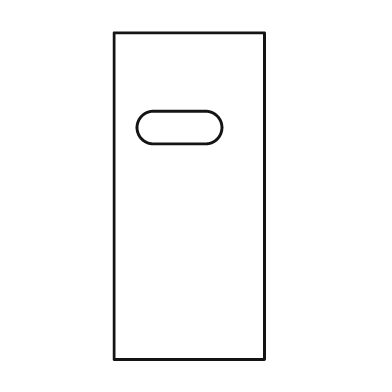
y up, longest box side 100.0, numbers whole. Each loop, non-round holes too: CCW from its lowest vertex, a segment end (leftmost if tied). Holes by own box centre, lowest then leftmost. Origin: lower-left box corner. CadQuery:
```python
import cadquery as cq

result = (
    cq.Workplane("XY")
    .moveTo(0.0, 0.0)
    .lineTo(46.0, 0.0)
    .lineTo(46.0, 100.0)
    .lineTo(0.0, 100.0)
    .close()
    .moveTo(12.0, 66.0)
    .lineTo(28.0, 66.0)
    .threePointArc((33.0, 71.0), (28.0, 76.0))
    .lineTo(12.0, 76.0)
    .threePointArc((7.0, 71.0), (12.0, 66.0))
    .close()
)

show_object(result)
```